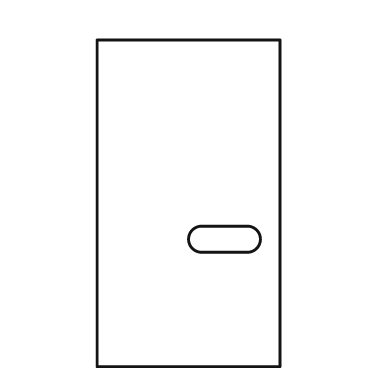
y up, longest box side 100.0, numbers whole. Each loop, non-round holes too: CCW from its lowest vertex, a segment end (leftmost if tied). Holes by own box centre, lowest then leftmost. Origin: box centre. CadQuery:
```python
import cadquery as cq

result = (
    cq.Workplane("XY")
    .moveTo(-28.0, -50.0)
    .lineTo(28.0, -50.0)
    .lineTo(28.0, 50.0)
    .lineTo(-28.0, 50.0)
    .close()
    .moveTo(4.0, -15.0)
    .lineTo(18.0, -15.0)
    .threePointArc((22.0, -11.0), (18.0, -7.0))
    .lineTo(4.0, -7.0)
    .threePointArc((0.0, -11.0), (4.0, -15.0))
    .close()
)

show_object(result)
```